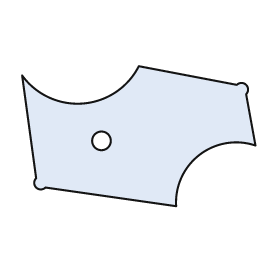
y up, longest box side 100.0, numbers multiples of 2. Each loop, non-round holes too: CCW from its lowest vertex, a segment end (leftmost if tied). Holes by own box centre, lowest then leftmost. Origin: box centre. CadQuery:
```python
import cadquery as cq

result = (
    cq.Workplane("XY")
    .moveTo(16.0, -30.0)
    .threePointArc((26.0, -8.0), (50.0, -4.0))
    .lineTo(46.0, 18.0)
    .threePointArc((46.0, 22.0), (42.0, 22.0))
    .lineTo(0.0, 30.0)
    .threePointArc((-24.0, 14.0), (-50.0, 26.0))
    .lineTo(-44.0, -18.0)
    .threePointArc((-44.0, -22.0), (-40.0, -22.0))
    .close()
    .moveTo(-16.0, -2.0)
    .circle(4.0)
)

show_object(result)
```